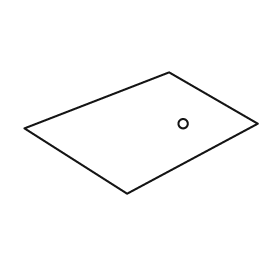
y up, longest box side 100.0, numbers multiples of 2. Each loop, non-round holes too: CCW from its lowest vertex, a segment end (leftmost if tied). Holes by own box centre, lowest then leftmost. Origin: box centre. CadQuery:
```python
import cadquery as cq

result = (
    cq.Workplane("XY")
    .moveTo(-6.0, -26.0)
    .lineTo(50.0, 4.0)
    .lineTo(12.0, 26.0)
    .lineTo(-50.0, 2.0)
    .close()
    .moveTo(18.0, 4.0)
    .circle(2.0)
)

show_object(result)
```